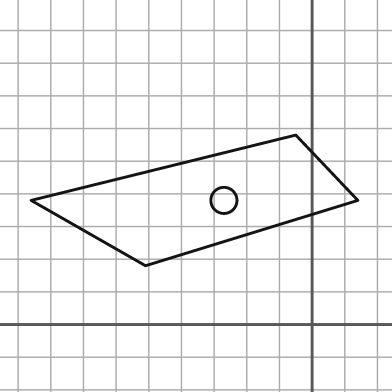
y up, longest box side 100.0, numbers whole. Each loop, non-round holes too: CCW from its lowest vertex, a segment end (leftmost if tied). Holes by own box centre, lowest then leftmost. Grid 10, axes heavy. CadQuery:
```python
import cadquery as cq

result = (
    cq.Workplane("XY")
    .moveTo(-51.0, 18.0)
    .lineTo(14.0, 38.0)
    .lineTo(-5.0, 58.0)
    .lineTo(-86.0, 38.0)
    .close()
    .moveTo(-27.0, 38.0)
    .circle(4.0)
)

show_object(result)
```